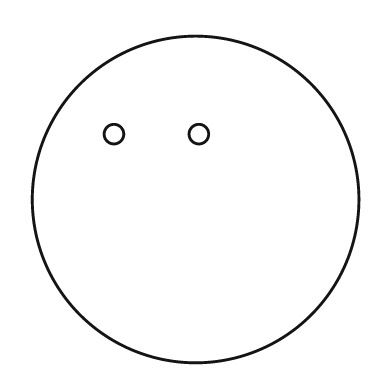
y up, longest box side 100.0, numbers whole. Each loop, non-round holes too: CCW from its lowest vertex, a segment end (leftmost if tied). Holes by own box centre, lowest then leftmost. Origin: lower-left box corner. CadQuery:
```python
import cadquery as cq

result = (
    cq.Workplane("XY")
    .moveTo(50.0, 50.0)
    .circle(50.0)
    .moveTo(25.0, 70.0)
    .circle(3.0)
    .moveTo(51.0, 70.0)
    .circle(3.0)
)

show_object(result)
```